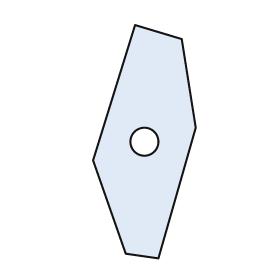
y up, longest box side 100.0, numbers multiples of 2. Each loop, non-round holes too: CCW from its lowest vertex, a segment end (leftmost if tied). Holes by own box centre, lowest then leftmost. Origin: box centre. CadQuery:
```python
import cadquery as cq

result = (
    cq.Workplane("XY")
    .moveTo(6.0, -50.0)
    .lineTo(22.0, 6.0)
    .lineTo(16.0, 44.0)
    .lineTo(-4.0, 50.0)
    .lineTo(-22.0, -8.0)
    .lineTo(-8.0, -48.0)
    .close()
    .moveTo(0.0, 0.0)
    .circle(6.0)
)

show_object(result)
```